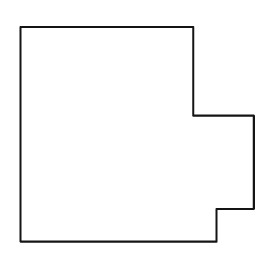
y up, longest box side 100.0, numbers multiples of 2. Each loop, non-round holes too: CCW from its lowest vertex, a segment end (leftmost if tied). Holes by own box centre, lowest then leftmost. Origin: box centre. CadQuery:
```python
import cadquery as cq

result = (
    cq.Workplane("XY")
    .moveTo(-50.0, -46.0)
    .lineTo(34.0, -46.0)
    .lineTo(34.0, -32.0)
    .lineTo(50.0, -32.0)
    .lineTo(50.0, 8.0)
    .lineTo(24.0, 8.0)
    .lineTo(24.0, 46.0)
    .lineTo(-50.0, 46.0)
    .close()
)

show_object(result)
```